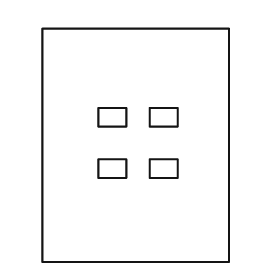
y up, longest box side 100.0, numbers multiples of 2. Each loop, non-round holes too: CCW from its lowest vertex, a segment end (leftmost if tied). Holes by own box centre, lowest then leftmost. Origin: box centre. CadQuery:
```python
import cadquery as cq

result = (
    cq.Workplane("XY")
    .moveTo(-40.0, -50.0)
    .lineTo(40.0, -50.0)
    .lineTo(40.0, 50.0)
    .lineTo(-40.0, 50.0)
    .close()
    .moveTo(-16.0, -14.0)
    .lineTo(-4.0, -14.0)
    .lineTo(-4.0, -6.0)
    .lineTo(-16.0, -6.0)
    .close()
    .moveTo(6.0, -14.0)
    .lineTo(18.0, -14.0)
    .lineTo(18.0, -6.0)
    .lineTo(6.0, -6.0)
    .close()
    .moveTo(-16.0, 8.0)
    .lineTo(-4.0, 8.0)
    .lineTo(-4.0, 16.0)
    .lineTo(-16.0, 16.0)
    .close()
    .moveTo(6.0, 8.0)
    .lineTo(18.0, 8.0)
    .lineTo(18.0, 16.0)
    .lineTo(6.0, 16.0)
    .close()
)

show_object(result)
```